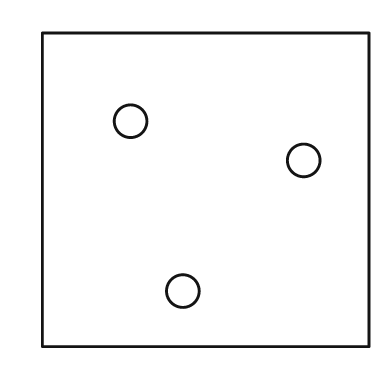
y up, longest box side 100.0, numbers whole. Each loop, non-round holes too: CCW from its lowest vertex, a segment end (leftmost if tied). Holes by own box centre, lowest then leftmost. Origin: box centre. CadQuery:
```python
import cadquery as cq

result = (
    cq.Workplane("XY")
    .moveTo(-50.0, -48.0)
    .lineTo(50.0, -48.0)
    .lineTo(50.0, 48.0)
    .lineTo(-50.0, 48.0)
    .close()
    .moveTo(-7.0, -31.0)
    .circle(5.0)
    .moveTo(30.0, 9.0)
    .circle(5.0)
    .moveTo(-23.0, 21.0)
    .circle(5.0)
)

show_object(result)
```